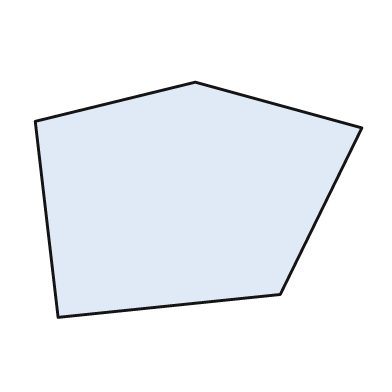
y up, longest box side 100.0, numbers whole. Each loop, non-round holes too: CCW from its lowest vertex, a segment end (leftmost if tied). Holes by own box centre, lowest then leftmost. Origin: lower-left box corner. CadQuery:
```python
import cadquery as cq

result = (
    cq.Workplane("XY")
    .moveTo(7.0, 0.0)
    .lineTo(75.0, 7.0)
    .lineTo(100.0, 58.0)
    .lineTo(49.0, 72.0)
    .lineTo(0.0, 60.0)
    .close()
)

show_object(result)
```